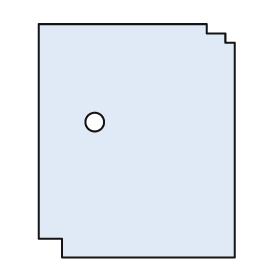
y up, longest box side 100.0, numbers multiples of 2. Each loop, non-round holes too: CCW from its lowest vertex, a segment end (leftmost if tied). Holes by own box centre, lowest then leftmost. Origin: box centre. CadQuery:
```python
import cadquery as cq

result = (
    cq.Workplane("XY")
    .moveTo(-32.0, -50.0)
    .lineTo(42.0, -50.0)
    .lineTo(42.0, 42.0)
    .lineTo(38.0, 42.0)
    .lineTo(38.0, 46.0)
    .lineTo(30.0, 46.0)
    .lineTo(30.0, 50.0)
    .lineTo(-42.0, 50.0)
    .lineTo(-42.0, -42.0)
    .lineTo(-32.0, -42.0)
    .close()
    .moveTo(-18.0, 8.0)
    .circle(4.0)
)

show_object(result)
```